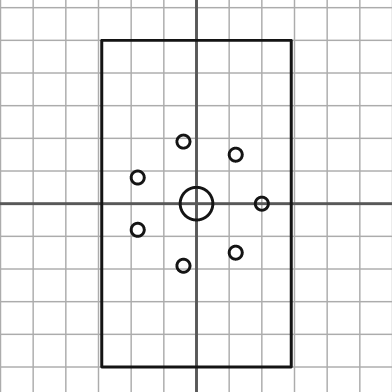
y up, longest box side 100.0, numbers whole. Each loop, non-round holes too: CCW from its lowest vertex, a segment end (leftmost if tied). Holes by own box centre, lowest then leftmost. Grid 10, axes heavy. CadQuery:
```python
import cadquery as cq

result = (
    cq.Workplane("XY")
    .moveTo(-29.0, -50.0)
    .lineTo(29.0, -50.0)
    .lineTo(29.0, 50.0)
    .lineTo(-29.0, 50.0)
    .close()
    .moveTo(-4.0, -19.0)
    .circle(2.0)
    .moveTo(12.0, -15.0)
    .circle(2.0)
    .moveTo(-18.0, -8.0)
    .circle(2.0)
    .moveTo(0.0, 0.0)
    .circle(5.0)
    .moveTo(20.0, 0.0)
    .circle(2.0)
    .moveTo(-18.0, 8.0)
    .circle(2.0)
    .moveTo(12.0, 15.0)
    .circle(2.0)
    .moveTo(-4.0, 19.0)
    .circle(2.0)
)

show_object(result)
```